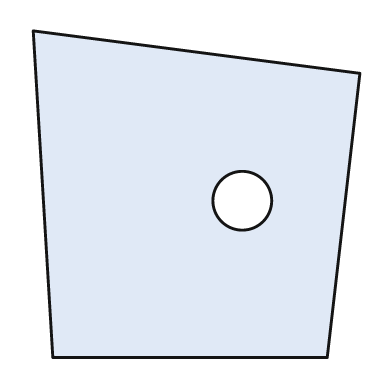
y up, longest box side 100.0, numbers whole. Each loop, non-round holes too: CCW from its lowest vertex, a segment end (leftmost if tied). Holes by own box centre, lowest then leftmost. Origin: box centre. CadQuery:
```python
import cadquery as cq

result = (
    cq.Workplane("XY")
    .moveTo(-44.0, -50.0)
    .lineTo(40.0, -50.0)
    .lineTo(50.0, 37.0)
    .lineTo(-50.0, 50.0)
    .close()
    .moveTo(14.0, -2.0)
    .circle(9.0)
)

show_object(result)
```